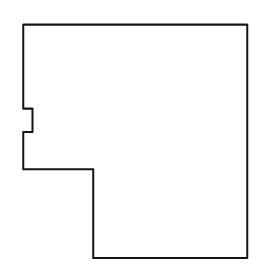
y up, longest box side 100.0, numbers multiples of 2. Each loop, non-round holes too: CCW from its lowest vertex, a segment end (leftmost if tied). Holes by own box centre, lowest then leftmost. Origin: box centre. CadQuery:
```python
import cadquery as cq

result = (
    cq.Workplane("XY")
    .moveTo(-18.0, -50.0)
    .lineTo(48.0, -50.0)
    .lineTo(48.0, 50.0)
    .lineTo(-48.0, 50.0)
    .lineTo(-48.0, 14.0)
    .lineTo(-44.0, 14.0)
    .lineTo(-44.0, 4.0)
    .lineTo(-48.0, 4.0)
    .lineTo(-48.0, -12.0)
    .lineTo(-18.0, -12.0)
    .close()
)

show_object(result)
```